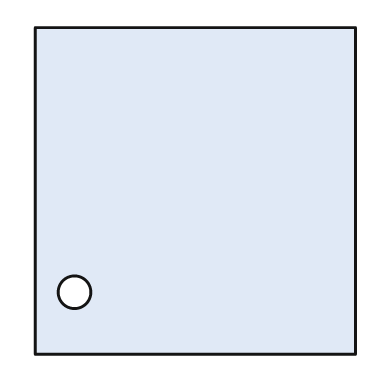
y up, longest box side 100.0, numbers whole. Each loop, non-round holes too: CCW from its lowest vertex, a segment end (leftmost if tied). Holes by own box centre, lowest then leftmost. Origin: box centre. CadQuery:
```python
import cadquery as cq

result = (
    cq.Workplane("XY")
    .moveTo(-49.0, -50.0)
    .lineTo(49.0, -50.0)
    .lineTo(49.0, 50.0)
    .lineTo(-49.0, 50.0)
    .close()
    .moveTo(-37.0, -31.0)
    .circle(5.0)
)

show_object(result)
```